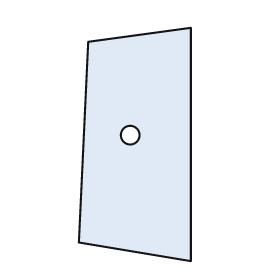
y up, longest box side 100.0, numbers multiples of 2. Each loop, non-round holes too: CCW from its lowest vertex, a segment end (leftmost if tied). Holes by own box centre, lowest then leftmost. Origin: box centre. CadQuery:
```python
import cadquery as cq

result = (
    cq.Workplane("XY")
    .moveTo(24.0, -50.0)
    .lineTo(24.0, 50.0)
    .lineTo(-20.0, 44.0)
    .lineTo(-24.0, -42.0)
    .close()
    .moveTo(-2.0, 4.0)
    .circle(4.0)
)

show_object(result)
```